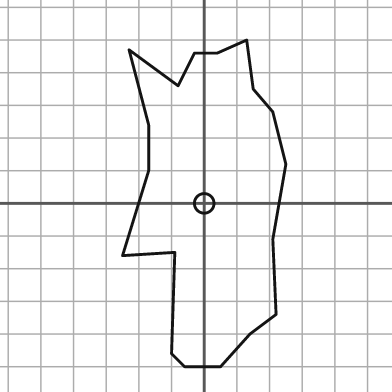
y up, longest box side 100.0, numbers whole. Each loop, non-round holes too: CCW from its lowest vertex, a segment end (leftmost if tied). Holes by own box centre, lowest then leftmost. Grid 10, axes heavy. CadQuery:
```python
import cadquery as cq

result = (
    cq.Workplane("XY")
    .moveTo(-6.0, -50.0)
    .lineTo(5.0, -50.0)
    .lineTo(14.0, -40.0)
    .lineTo(22.0, -34.0)
    .lineTo(21.0, -11.0)
    .lineTo(25.0, 12.0)
    .lineTo(21.0, 28.0)
    .lineTo(15.0, 35.0)
    .lineTo(13.0, 50.0)
    .lineTo(4.0, 46.0)
    .lineTo(-3.0, 46.0)
    .lineTo(-8.0, 36.0)
    .lineTo(-23.0, 47.0)
    .lineTo(-17.0, 24.0)
    .lineTo(-17.0, 10.0)
    .lineTo(-25.0, -16.0)
    .lineTo(-9.0, -15.0)
    .lineTo(-10.0, -46.0)
    .close()
    .moveTo(0.0, 0.0)
    .circle(3.0)
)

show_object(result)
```